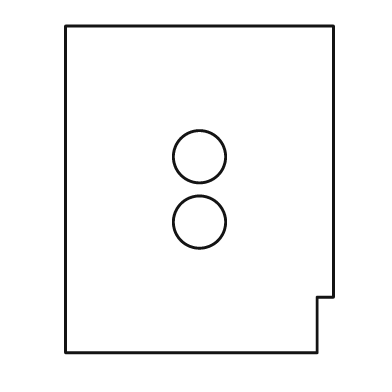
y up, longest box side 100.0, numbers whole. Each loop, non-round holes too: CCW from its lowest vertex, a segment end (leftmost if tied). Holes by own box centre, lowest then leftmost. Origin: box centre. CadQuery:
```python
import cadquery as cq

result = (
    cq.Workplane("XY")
    .moveTo(-41.0, -50.0)
    .lineTo(36.0, -50.0)
    .lineTo(36.0, -33.0)
    .lineTo(41.0, -33.0)
    .lineTo(41.0, 50.0)
    .lineTo(-41.0, 50.0)
    .close()
    .moveTo(0.0, -10.0)
    .circle(8.0)
    .moveTo(0.0, 10.0)
    .circle(8.0)
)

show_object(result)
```